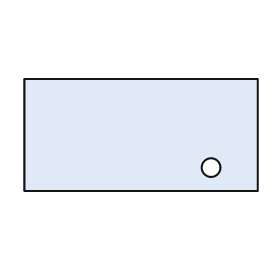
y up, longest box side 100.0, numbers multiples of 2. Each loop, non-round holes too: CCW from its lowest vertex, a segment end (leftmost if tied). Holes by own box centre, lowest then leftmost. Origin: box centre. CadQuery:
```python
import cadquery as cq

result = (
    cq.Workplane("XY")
    .moveTo(-50.0, -24.0)
    .lineTo(50.0, -24.0)
    .lineTo(50.0, 24.0)
    .lineTo(-50.0, 24.0)
    .close()
    .moveTo(30.0, -14.0)
    .circle(4.0)
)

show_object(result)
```